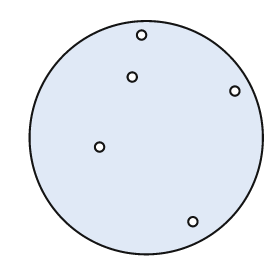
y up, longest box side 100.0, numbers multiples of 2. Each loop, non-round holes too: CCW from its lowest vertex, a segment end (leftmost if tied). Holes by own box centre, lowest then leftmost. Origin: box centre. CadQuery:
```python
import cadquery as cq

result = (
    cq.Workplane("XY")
    .moveTo(0.0, 0.0)
    .circle(50.0)
    .moveTo(20.0, -36.0)
    .circle(2.0)
    .moveTo(-20.0, -4.0)
    .circle(2.0)
    .moveTo(38.0, 20.0)
    .circle(2.0)
    .moveTo(-6.0, 26.0)
    .circle(2.0)
    .moveTo(-2.0, 44.0)
    .circle(2.0)
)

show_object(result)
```